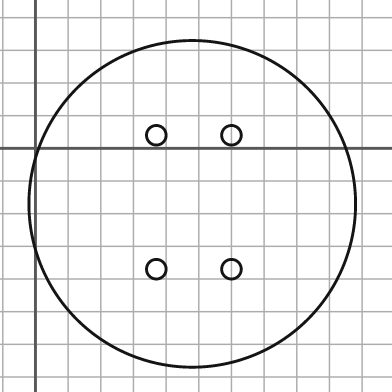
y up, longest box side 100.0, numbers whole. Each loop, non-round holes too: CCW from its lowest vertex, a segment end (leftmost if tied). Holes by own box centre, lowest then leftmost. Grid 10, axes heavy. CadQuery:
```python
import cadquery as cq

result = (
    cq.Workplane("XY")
    .moveTo(48.0, -17.0)
    .circle(50.0)
    .moveTo(37.0, -37.0)
    .circle(3.0)
    .moveTo(60.0, -37.0)
    .circle(3.0)
    .moveTo(37.0, 4.0)
    .circle(3.0)
    .moveTo(60.0, 4.0)
    .circle(3.0)
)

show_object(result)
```